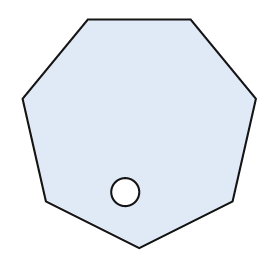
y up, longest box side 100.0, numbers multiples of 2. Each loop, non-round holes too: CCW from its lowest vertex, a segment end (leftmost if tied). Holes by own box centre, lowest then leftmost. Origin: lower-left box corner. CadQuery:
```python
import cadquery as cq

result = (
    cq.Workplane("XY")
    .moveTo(50.0, 0.0)
    .lineTo(90.0, 20.0)
    .lineTo(100.0, 64.0)
    .lineTo(72.0, 98.0)
    .lineTo(28.0, 98.0)
    .lineTo(0.0, 64.0)
    .lineTo(10.0, 20.0)
    .close()
    .moveTo(44.0, 24.0)
    .circle(6.0)
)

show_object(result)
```